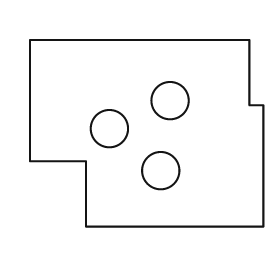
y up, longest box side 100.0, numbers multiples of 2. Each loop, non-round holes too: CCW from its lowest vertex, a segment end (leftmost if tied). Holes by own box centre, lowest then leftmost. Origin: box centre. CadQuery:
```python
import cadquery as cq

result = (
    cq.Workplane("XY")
    .moveTo(-26.0, -40.0)
    .lineTo(50.0, -40.0)
    .lineTo(50.0, 12.0)
    .lineTo(44.0, 12.0)
    .lineTo(44.0, 40.0)
    .lineTo(-50.0, 40.0)
    .lineTo(-50.0, -12.0)
    .lineTo(-26.0, -12.0)
    .close()
    .moveTo(6.0, -16.0)
    .circle(8.0)
    .moveTo(-16.0, 2.0)
    .circle(8.0)
    .moveTo(10.0, 14.0)
    .circle(8.0)
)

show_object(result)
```